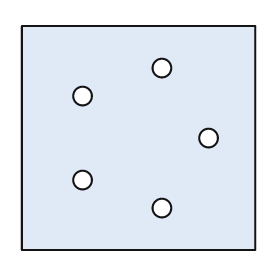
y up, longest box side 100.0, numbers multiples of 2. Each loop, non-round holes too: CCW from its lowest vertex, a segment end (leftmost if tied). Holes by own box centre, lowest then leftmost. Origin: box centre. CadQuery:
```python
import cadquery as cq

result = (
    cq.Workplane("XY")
    .moveTo(-50.0, -48.0)
    .lineTo(50.0, -48.0)
    .lineTo(50.0, 48.0)
    .lineTo(-50.0, 48.0)
    .close()
    .moveTo(10.0, -30.0)
    .circle(4.0)
    .moveTo(-24.0, -18.0)
    .circle(4.0)
    .moveTo(30.0, 0.0)
    .circle(4.0)
    .moveTo(-24.0, 18.0)
    .circle(4.0)
    .moveTo(10.0, 30.0)
    .circle(4.0)
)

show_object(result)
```